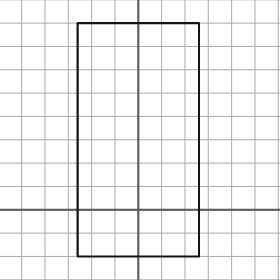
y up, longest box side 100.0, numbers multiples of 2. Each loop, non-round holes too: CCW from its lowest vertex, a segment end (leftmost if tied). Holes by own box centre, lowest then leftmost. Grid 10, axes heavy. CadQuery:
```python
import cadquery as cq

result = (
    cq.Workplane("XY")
    .moveTo(-26.0, -20.0)
    .lineTo(26.0, -20.0)
    .lineTo(26.0, 80.0)
    .lineTo(-26.0, 80.0)
    .close()
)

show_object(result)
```